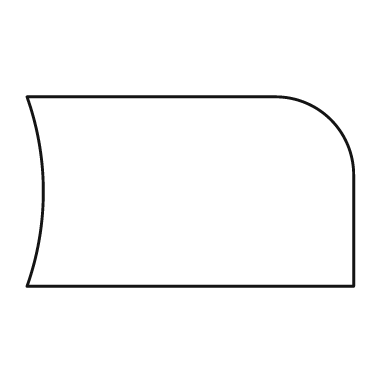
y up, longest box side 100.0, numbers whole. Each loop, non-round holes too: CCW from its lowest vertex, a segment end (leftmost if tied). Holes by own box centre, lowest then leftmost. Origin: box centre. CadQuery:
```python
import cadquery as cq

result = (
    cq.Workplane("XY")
    .moveTo(-50.0, -29.0)
    .lineTo(50.0, -29.0)
    .lineTo(50.0, 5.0)
    .threePointArc((43.0, 22.0), (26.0, 29.0))
    .lineTo(-50.0, 29.0)
    .threePointArc((-45.0, 0.0), (-50.0, -29.0))
    .close()
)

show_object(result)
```